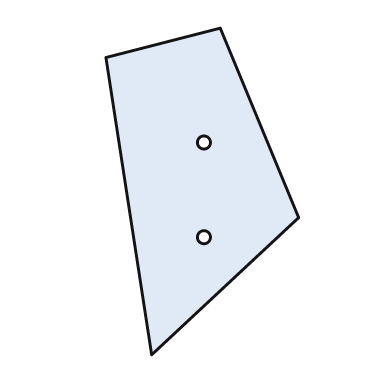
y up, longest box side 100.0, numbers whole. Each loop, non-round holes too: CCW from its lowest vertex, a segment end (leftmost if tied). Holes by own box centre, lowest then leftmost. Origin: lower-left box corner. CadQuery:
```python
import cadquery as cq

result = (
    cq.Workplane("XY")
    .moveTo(14.0, 0.0)
    .lineTo(59.0, 42.0)
    .lineTo(35.0, 100.0)
    .lineTo(0.0, 91.0)
    .close()
    .moveTo(30.0, 36.0)
    .circle(2.0)
    .moveTo(30.0, 65.0)
    .circle(2.0)
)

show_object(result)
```